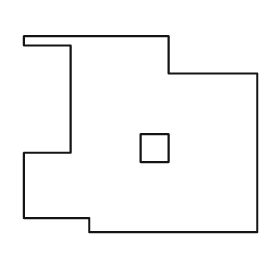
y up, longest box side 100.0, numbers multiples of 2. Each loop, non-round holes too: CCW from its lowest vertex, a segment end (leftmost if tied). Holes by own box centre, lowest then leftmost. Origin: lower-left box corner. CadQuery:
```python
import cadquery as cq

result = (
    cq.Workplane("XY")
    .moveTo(28.0, 0.0)
    .lineTo(100.0, 0.0)
    .lineTo(100.0, 68.0)
    .lineTo(62.0, 68.0)
    .lineTo(62.0, 84.0)
    .lineTo(0.0, 84.0)
    .lineTo(0.0, 80.0)
    .lineTo(20.0, 80.0)
    .lineTo(20.0, 34.0)
    .lineTo(0.0, 34.0)
    .lineTo(0.0, 6.0)
    .lineTo(28.0, 6.0)
    .close()
    .moveTo(50.0, 30.0)
    .lineTo(62.0, 30.0)
    .lineTo(62.0, 42.0)
    .lineTo(50.0, 42.0)
    .close()
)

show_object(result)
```